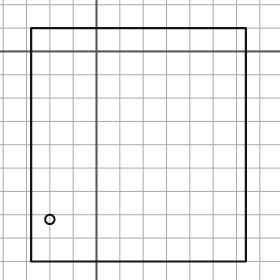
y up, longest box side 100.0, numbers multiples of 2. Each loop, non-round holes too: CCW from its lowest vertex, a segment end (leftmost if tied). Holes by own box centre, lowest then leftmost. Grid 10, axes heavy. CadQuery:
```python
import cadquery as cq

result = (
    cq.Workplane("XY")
    .moveTo(-28.0, -90.0)
    .lineTo(64.0, -90.0)
    .lineTo(64.0, 10.0)
    .lineTo(-28.0, 10.0)
    .close()
    .moveTo(-20.0, -72.0)
    .circle(2.0)
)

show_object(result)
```